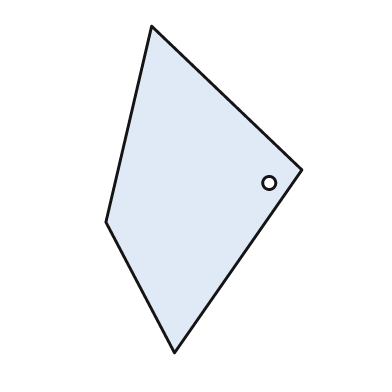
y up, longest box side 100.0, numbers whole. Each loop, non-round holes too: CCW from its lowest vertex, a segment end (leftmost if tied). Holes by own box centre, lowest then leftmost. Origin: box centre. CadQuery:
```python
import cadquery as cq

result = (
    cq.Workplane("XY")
    .moveTo(-9.0, -50.0)
    .lineTo(30.0, 6.0)
    .lineTo(-16.0, 50.0)
    .lineTo(-30.0, -10.0)
    .close()
    .moveTo(20.0, 2.0)
    .circle(2.0)
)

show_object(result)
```